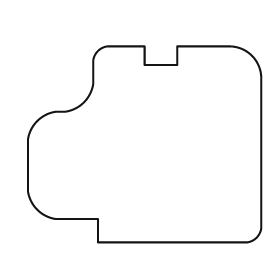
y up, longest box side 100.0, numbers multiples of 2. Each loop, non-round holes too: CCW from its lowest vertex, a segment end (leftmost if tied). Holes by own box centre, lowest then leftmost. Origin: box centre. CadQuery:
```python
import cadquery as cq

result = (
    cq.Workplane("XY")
    .moveTo(-20.0, -42.0)
    .lineTo(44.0, -42.0)
    .threePointArc((48.0, -40.0), (50.0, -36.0))
    .lineTo(50.0, 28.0)
    .threePointArc((46.0, 38.0), (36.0, 42.0))
    .lineTo(14.0, 42.0)
    .lineTo(14.0, 34.0)
    .lineTo(0.0, 34.0)
    .lineTo(0.0, 42.0)
    .lineTo(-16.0, 42.0)
    .threePointArc((-20.0, 40.0), (-22.0, 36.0))
    .lineTo(-22.0, 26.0)
    .threePointArc((-26.0, 18.0), (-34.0, 14.0))
    .lineTo(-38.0, 14.0)
    .threePointArc((-46.0, 10.0), (-50.0, 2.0))
    .lineTo(-50.0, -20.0)
    .threePointArc((-46.0, -28.0), (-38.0, -32.0))
    .lineTo(-20.0, -32.0)
    .close()
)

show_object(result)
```